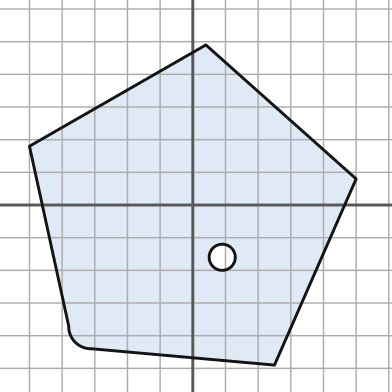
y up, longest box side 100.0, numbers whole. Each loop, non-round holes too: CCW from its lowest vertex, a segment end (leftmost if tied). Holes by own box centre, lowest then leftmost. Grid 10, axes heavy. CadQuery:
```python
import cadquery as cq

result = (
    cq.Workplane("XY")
    .moveTo(25.0, -49.0)
    .lineTo(50.0, 8.0)
    .lineTo(4.0, 49.0)
    .lineTo(-50.0, 18.0)
    .lineTo(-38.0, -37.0)
    .threePointArc((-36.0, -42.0), (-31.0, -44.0))
    .close()
    .moveTo(9.0, -16.0)
    .circle(4.0)
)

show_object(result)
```